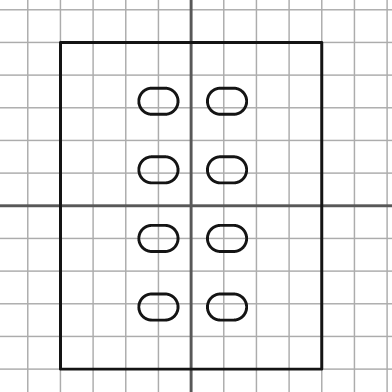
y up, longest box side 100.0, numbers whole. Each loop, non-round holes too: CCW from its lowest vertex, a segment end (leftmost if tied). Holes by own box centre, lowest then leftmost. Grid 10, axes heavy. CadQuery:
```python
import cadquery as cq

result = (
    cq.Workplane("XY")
    .moveTo(-40.0, -50.0)
    .lineTo(40.0, -50.0)
    .lineTo(40.0, 50.0)
    .lineTo(-40.0, 50.0)
    .close()
    .moveTo(-12.0, -35.0)
    .lineTo(-8.0, -35.0)
    .threePointArc((-4.0, -31.0), (-8.0, -27.0))
    .lineTo(-12.0, -27.0)
    .threePointArc((-16.0, -31.0), (-12.0, -35.0))
    .close()
    .moveTo(9.0, -35.0)
    .lineTo(13.0, -35.0)
    .threePointArc((17.0, -31.0), (13.0, -27.0))
    .lineTo(9.0, -27.0)
    .threePointArc((5.0, -31.0), (9.0, -35.0))
    .close()
    .moveTo(-12.0, -14.0)
    .lineTo(-8.0, -14.0)
    .threePointArc((-4.0, -10.0), (-8.0, -6.0))
    .lineTo(-12.0, -6.0)
    .threePointArc((-16.0, -10.0), (-12.0, -14.0))
    .close()
    .moveTo(9.0, -14.0)
    .lineTo(13.0, -14.0)
    .threePointArc((17.0, -10.0), (13.0, -6.0))
    .lineTo(9.0, -6.0)
    .threePointArc((5.0, -10.0), (9.0, -14.0))
    .close()
    .moveTo(-12.0, 7.0)
    .lineTo(-8.0, 7.0)
    .threePointArc((-4.0, 11.0), (-8.0, 15.0))
    .lineTo(-12.0, 15.0)
    .threePointArc((-16.0, 11.0), (-12.0, 7.0))
    .close()
    .moveTo(9.0, 7.0)
    .lineTo(13.0, 7.0)
    .threePointArc((17.0, 11.0), (13.0, 15.0))
    .lineTo(9.0, 15.0)
    .threePointArc((5.0, 11.0), (9.0, 7.0))
    .close()
    .moveTo(-12.0, 28.0)
    .lineTo(-8.0, 28.0)
    .threePointArc((-4.0, 32.0), (-8.0, 36.0))
    .lineTo(-12.0, 36.0)
    .threePointArc((-16.0, 32.0), (-12.0, 28.0))
    .close()
    .moveTo(9.0, 28.0)
    .lineTo(13.0, 28.0)
    .threePointArc((17.0, 32.0), (13.0, 36.0))
    .lineTo(9.0, 36.0)
    .threePointArc((5.0, 32.0), (9.0, 28.0))
    .close()
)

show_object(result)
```